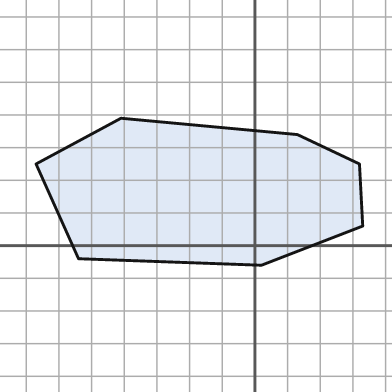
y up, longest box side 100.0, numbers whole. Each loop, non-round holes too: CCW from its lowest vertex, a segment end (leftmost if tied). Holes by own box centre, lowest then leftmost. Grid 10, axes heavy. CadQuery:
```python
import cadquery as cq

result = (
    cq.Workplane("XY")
    .moveTo(2.0, -6.0)
    .lineTo(33.0, 6.0)
    .lineTo(32.0, 25.0)
    .lineTo(13.0, 34.0)
    .lineTo(-41.0, 39.0)
    .lineTo(-67.0, 25.0)
    .lineTo(-54.0, -4.0)
    .close()
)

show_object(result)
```